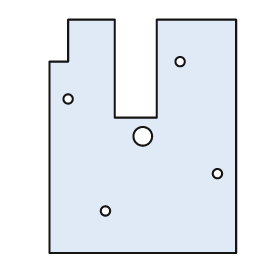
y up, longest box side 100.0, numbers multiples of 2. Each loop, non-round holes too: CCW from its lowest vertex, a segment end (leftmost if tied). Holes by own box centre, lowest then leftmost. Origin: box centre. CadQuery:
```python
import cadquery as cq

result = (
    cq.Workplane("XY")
    .moveTo(-40.0, -50.0)
    .lineTo(40.0, -50.0)
    .lineTo(40.0, 50.0)
    .lineTo(6.0, 50.0)
    .lineTo(6.0, 8.0)
    .lineTo(-12.0, 8.0)
    .lineTo(-12.0, 50.0)
    .lineTo(-32.0, 50.0)
    .lineTo(-32.0, 32.0)
    .lineTo(-40.0, 32.0)
    .close()
    .moveTo(-16.0, -32.0)
    .circle(2.0)
    .moveTo(32.0, -16.0)
    .circle(2.0)
    .moveTo(0.0, 0.0)
    .circle(4.0)
    .moveTo(-32.0, 16.0)
    .circle(2.0)
    .moveTo(16.0, 32.0)
    .circle(2.0)
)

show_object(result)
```